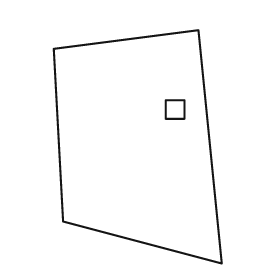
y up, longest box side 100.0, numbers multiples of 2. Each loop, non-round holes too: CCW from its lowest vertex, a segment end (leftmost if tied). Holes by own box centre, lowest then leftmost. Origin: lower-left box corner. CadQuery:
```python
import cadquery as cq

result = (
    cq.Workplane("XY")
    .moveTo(72.0, 0.0)
    .lineTo(62.0, 100.0)
    .lineTo(0.0, 92.0)
    .lineTo(4.0, 18.0)
    .close()
    .moveTo(48.0, 62.0)
    .lineTo(56.0, 62.0)
    .lineTo(56.0, 70.0)
    .lineTo(48.0, 70.0)
    .close()
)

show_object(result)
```